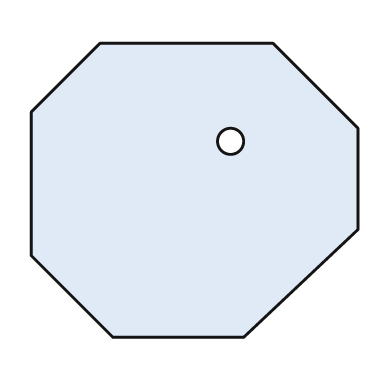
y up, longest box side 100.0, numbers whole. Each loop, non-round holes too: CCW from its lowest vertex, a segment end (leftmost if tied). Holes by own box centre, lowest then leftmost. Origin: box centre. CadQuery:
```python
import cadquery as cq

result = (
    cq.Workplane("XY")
    .moveTo(-25.0, -45.0)
    .lineTo(15.0, -45.0)
    .lineTo(50.0, -12.0)
    .lineTo(50.0, 19.0)
    .lineTo(24.0, 45.0)
    .lineTo(-29.0, 45.0)
    .lineTo(-50.0, 24.0)
    .lineTo(-50.0, -20.0)
    .close()
    .moveTo(11.0, 15.0)
    .circle(4.0)
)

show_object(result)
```